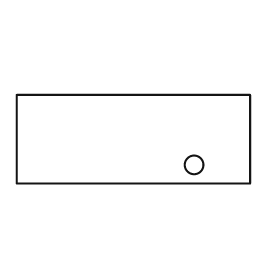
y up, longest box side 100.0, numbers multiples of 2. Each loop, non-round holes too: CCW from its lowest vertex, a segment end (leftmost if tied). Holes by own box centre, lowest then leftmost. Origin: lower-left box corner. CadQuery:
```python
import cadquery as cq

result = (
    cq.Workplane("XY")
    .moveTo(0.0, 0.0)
    .lineTo(100.0, 0.0)
    .lineTo(100.0, 38.0)
    .lineTo(0.0, 38.0)
    .close()
    .moveTo(76.0, 8.0)
    .circle(4.0)
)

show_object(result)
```